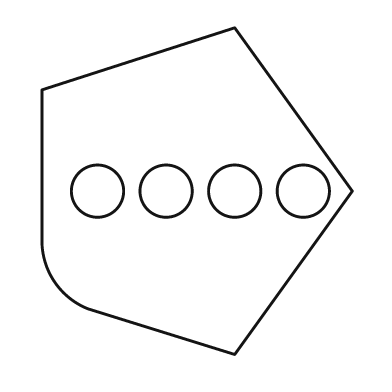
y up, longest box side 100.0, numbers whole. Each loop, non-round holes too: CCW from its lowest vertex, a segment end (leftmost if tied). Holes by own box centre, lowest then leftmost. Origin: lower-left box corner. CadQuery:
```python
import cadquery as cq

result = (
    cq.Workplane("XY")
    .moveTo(59.0, 0.0)
    .lineTo(95.0, 50.0)
    .lineTo(59.0, 100.0)
    .lineTo(0.0, 81.0)
    .lineTo(0.0, 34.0)
    .threePointArc((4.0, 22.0), (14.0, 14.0))
    .close()
    .moveTo(17.0, 50.0)
    .circle(8.0)
    .moveTo(38.0, 50.0)
    .circle(8.0)
    .moveTo(59.0, 50.0)
    .circle(8.0)
    .moveTo(80.0, 50.0)
    .circle(8.0)
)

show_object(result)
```